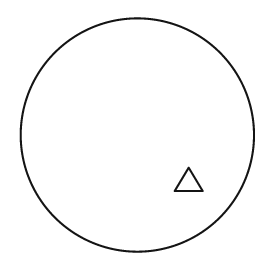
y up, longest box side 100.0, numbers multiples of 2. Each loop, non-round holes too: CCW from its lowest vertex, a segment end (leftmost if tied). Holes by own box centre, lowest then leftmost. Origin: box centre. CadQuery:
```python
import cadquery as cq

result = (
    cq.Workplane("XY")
    .moveTo(0.0, 0.0)
    .circle(50.0)
    .moveTo(16.0, -24.0)
    .lineTo(28.0, -24.0)
    .lineTo(22.0, -14.0)
    .close()
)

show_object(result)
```